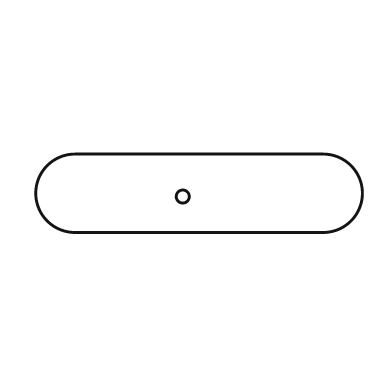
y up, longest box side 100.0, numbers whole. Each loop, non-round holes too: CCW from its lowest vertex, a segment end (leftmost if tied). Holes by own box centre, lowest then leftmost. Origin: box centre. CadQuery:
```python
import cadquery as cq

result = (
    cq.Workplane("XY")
    .moveTo(-38.0, -12.0)
    .lineTo(38.0, -12.0)
    .threePointArc((50.0, 0.0), (38.0, 12.0))
    .lineTo(-38.0, 12.0)
    .threePointArc((-50.0, 0.0), (-38.0, -12.0))
    .close()
    .moveTo(-5.0, -1.0)
    .circle(2.0)
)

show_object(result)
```